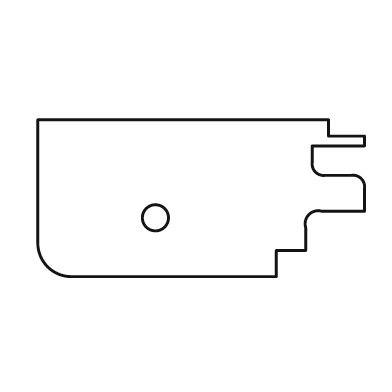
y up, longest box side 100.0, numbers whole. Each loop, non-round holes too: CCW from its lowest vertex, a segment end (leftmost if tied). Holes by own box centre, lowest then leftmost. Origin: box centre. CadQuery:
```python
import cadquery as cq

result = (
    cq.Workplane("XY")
    .moveTo(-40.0, -24.0)
    .lineTo(23.0, -24.0)
    .lineTo(23.0, -16.0)
    .lineTo(32.0, -16.0)
    .lineTo(32.0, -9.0)
    .threePointArc((33.0, -5.0), (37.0, -4.0))
    .lineTo(50.0, -4.0)
    .lineTo(50.0, 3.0)
    .threePointArc((49.0, 6.0), (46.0, 7.0))
    .lineTo(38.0, 7.0)
    .threePointArc((35.0, 8.0), (34.0, 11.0))
    .lineTo(34.0, 16.0)
    .lineTo(50.0, 16.0)
    .lineTo(50.0, 19.0)
    .lineTo(39.0, 19.0)
    .lineTo(39.0, 24.0)
    .lineTo(-50.0, 24.0)
    .lineTo(-50.0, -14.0)
    .threePointArc((-47.0, -21.0), (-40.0, -24.0))
    .close()
    .moveTo(-14.0, -6.0)
    .circle(4.0)
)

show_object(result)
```